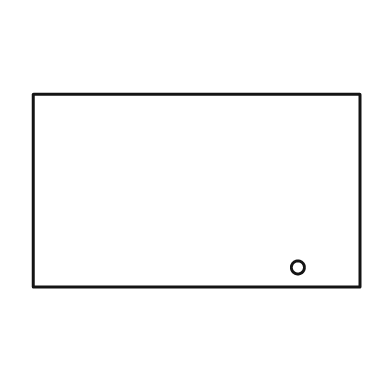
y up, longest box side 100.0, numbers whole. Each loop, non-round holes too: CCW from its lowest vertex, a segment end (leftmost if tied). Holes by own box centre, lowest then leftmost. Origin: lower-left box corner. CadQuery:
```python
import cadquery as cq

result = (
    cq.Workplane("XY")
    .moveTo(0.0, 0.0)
    .lineTo(100.0, 0.0)
    .lineTo(100.0, 59.0)
    .lineTo(0.0, 59.0)
    .close()
    .moveTo(81.0, 6.0)
    .circle(2.0)
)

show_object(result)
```